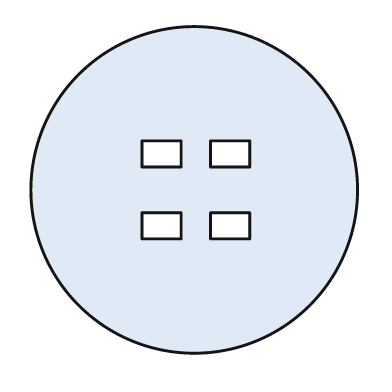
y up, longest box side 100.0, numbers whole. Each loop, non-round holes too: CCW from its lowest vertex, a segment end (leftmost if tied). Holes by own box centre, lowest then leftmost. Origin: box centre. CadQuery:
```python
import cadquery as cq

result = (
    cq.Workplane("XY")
    .moveTo(0.0, 0.0)
    .circle(50.0)
    .moveTo(-16.0, -15.0)
    .lineTo(-4.0, -15.0)
    .lineTo(-4.0, -7.0)
    .lineTo(-16.0, -7.0)
    .close()
    .moveTo(5.0, -15.0)
    .lineTo(17.0, -15.0)
    .lineTo(17.0, -7.0)
    .lineTo(5.0, -7.0)
    .close()
    .moveTo(-16.0, 7.0)
    .lineTo(-4.0, 7.0)
    .lineTo(-4.0, 15.0)
    .lineTo(-16.0, 15.0)
    .close()
    .moveTo(5.0, 7.0)
    .lineTo(17.0, 7.0)
    .lineTo(17.0, 15.0)
    .lineTo(5.0, 15.0)
    .close()
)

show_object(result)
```